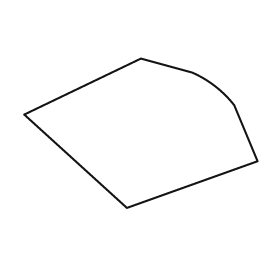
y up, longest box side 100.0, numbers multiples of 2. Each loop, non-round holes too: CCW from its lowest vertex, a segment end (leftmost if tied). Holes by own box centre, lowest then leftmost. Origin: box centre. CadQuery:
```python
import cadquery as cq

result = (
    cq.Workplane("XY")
    .moveTo(-6.0, -32.0)
    .lineTo(50.0, -12.0)
    .lineTo(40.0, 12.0)
    .threePointArc((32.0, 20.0), (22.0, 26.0))
    .lineTo(0.0, 32.0)
    .lineTo(-50.0, 8.0)
    .close()
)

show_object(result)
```